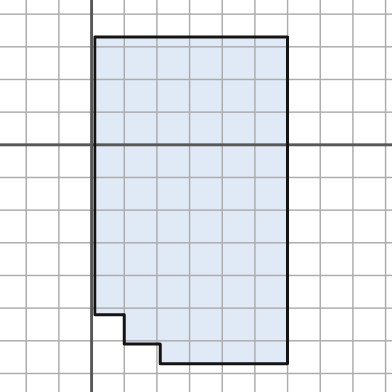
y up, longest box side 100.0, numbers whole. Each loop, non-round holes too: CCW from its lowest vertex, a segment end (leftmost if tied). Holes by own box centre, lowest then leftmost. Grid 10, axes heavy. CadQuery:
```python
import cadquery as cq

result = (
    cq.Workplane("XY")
    .moveTo(21.0, -67.0)
    .lineTo(60.0, -67.0)
    .lineTo(60.0, 33.0)
    .lineTo(1.0, 33.0)
    .lineTo(1.0, -52.0)
    .lineTo(10.0, -52.0)
    .lineTo(10.0, -61.0)
    .lineTo(21.0, -61.0)
    .close()
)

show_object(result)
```